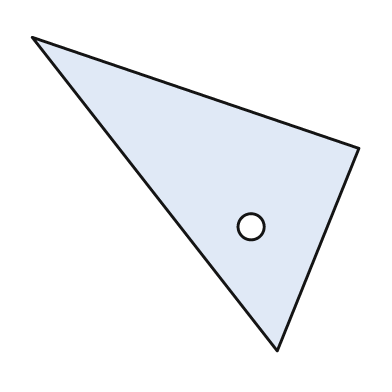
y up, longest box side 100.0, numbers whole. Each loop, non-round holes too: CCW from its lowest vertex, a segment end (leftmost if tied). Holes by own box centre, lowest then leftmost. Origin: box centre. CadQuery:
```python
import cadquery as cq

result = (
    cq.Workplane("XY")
    .moveTo(25.0, -48.0)
    .lineTo(50.0, 14.0)
    .lineTo(-50.0, 48.0)
    .close()
    .moveTo(17.0, -10.0)
    .circle(4.0)
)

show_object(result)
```